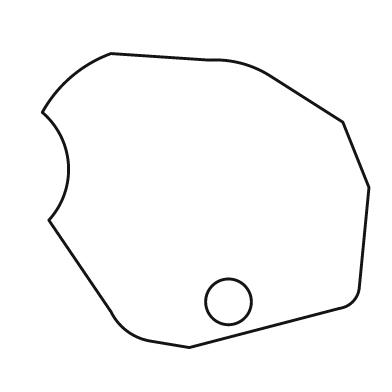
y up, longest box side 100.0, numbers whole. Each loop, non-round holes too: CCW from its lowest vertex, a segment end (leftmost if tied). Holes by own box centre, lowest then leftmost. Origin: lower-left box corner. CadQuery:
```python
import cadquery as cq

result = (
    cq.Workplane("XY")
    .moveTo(45.0, 0.0)
    .lineTo(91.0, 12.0)
    .threePointArc((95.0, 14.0), (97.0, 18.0))
    .lineTo(100.0, 49.0)
    .lineTo(92.0, 69.0)
    .lineTo(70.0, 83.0)
    .threePointArc((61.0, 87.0), (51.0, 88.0))
    .lineTo(21.0, 90.0)
    .threePointArc((9.0, 83.0), (0.0, 72.0))
    .threePointArc((8.0, 56.0), (2.0, 39.0))
    .lineTo(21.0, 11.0)
    .threePointArc((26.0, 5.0), (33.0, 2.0))
    .close()
    .moveTo(57.0, 14.0)
    .circle(7.0)
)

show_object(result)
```